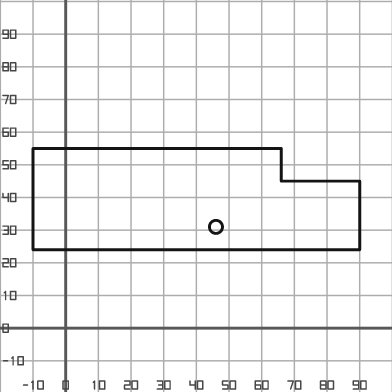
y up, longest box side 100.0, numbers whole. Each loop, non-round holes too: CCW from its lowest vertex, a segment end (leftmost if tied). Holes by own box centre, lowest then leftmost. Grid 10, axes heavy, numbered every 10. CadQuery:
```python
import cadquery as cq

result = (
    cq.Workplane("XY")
    .moveTo(-10.0, 24.0)
    .lineTo(90.0, 24.0)
    .lineTo(90.0, 45.0)
    .lineTo(66.0, 45.0)
    .lineTo(66.0, 55.0)
    .lineTo(-10.0, 55.0)
    .close()
    .moveTo(46.0, 31.0)
    .circle(2.0)
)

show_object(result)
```